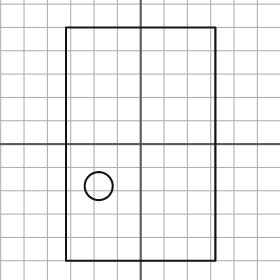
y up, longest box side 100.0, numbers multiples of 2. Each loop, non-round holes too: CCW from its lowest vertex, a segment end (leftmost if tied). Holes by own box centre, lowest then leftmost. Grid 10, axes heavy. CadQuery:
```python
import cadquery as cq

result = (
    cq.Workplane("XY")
    .moveTo(-32.0, -50.0)
    .lineTo(32.0, -50.0)
    .lineTo(32.0, 50.0)
    .lineTo(-32.0, 50.0)
    .close()
    .moveTo(-18.0, -18.0)
    .circle(6.0)
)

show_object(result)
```